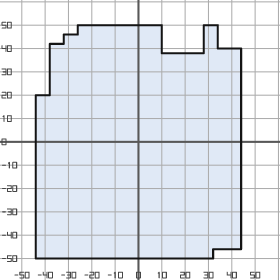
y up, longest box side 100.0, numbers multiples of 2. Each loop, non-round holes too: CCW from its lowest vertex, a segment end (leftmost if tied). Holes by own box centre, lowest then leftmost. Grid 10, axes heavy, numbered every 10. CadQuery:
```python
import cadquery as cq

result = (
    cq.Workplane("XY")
    .moveTo(-44.0, -50.0)
    .lineTo(32.0, -50.0)
    .lineTo(32.0, -46.0)
    .lineTo(44.0, -46.0)
    .lineTo(44.0, 40.0)
    .lineTo(34.0, 40.0)
    .lineTo(34.0, 50.0)
    .lineTo(28.0, 50.0)
    .lineTo(28.0, 38.0)
    .lineTo(10.0, 38.0)
    .lineTo(10.0, 50.0)
    .lineTo(-26.0, 50.0)
    .lineTo(-26.0, 46.0)
    .lineTo(-32.0, 46.0)
    .lineTo(-32.0, 42.0)
    .lineTo(-38.0, 42.0)
    .lineTo(-38.0, 20.0)
    .lineTo(-44.0, 20.0)
    .close()
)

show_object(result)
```